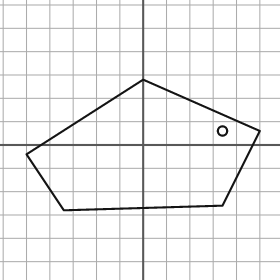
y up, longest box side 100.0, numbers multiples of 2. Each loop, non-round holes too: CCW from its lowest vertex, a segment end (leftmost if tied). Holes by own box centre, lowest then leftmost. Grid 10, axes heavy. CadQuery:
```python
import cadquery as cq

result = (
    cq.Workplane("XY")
    .moveTo(-34.0, -28.0)
    .lineTo(34.0, -26.0)
    .lineTo(50.0, 6.0)
    .lineTo(0.0, 28.0)
    .lineTo(-50.0, -4.0)
    .close()
    .moveTo(34.0, 6.0)
    .circle(2.0)
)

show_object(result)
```